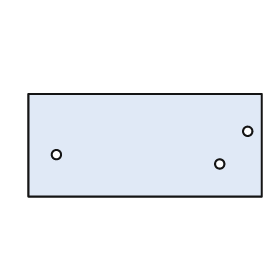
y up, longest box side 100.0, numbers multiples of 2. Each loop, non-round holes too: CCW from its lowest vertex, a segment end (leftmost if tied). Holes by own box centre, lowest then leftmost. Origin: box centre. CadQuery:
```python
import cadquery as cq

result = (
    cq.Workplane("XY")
    .moveTo(-50.0, -22.0)
    .lineTo(50.0, -22.0)
    .lineTo(50.0, 22.0)
    .lineTo(-50.0, 22.0)
    .close()
    .moveTo(32.0, -8.0)
    .circle(2.0)
    .moveTo(-38.0, -4.0)
    .circle(2.0)
    .moveTo(44.0, 6.0)
    .circle(2.0)
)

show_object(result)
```